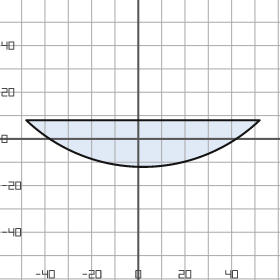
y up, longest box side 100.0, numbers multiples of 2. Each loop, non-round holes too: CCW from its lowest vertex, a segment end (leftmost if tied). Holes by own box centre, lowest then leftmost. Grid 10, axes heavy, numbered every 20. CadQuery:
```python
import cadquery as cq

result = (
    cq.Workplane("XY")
    .moveTo(-48.0, 8.0)
    .threePointArc((2.0, -12.0), (52.0, 8.0))
    .close()
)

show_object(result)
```